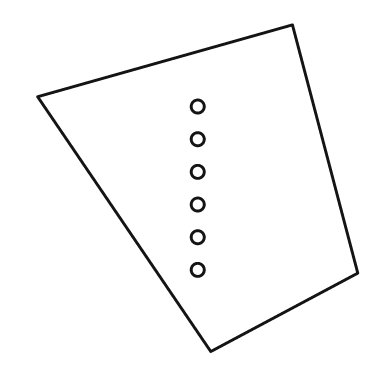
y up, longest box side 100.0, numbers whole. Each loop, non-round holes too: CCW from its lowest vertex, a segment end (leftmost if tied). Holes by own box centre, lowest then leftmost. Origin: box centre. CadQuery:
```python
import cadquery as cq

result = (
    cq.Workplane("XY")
    .moveTo(4.0, -50.0)
    .lineTo(49.0, -26.0)
    .lineTo(29.0, 50.0)
    .lineTo(-49.0, 28.0)
    .close()
    .moveTo(0.0, -25.0)
    .circle(2.0)
    .moveTo(0.0, -15.0)
    .circle(2.0)
    .moveTo(0.0, -5.0)
    .circle(2.0)
    .moveTo(0.0, 5.0)
    .circle(2.0)
    .moveTo(0.0, 15.0)
    .circle(2.0)
    .moveTo(0.0, 25.0)
    .circle(2.0)
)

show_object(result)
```